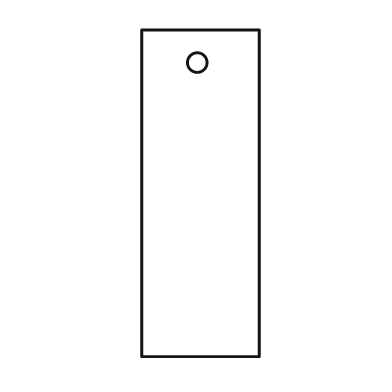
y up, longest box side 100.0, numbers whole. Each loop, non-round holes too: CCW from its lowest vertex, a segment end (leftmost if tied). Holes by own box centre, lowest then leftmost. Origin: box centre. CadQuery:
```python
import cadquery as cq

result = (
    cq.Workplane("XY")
    .moveTo(-18.0, -50.0)
    .lineTo(18.0, -50.0)
    .lineTo(18.0, 50.0)
    .lineTo(-18.0, 50.0)
    .close()
    .moveTo(-1.0, 40.0)
    .circle(3.0)
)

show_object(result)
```